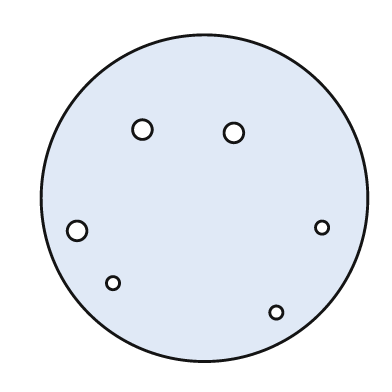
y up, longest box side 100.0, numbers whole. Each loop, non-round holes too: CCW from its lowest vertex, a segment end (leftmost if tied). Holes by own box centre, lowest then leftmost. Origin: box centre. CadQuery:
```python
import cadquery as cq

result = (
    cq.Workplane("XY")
    .moveTo(0.0, 0.0)
    .circle(50.0)
    .moveTo(22.0, -35.0)
    .circle(2.0)
    .moveTo(-28.0, -26.0)
    .circle(2.0)
    .moveTo(-39.0, -10.0)
    .circle(3.0)
    .moveTo(36.0, -9.0)
    .circle(2.0)
    .moveTo(9.0, 20.0)
    .circle(3.0)
    .moveTo(-19.0, 21.0)
    .circle(3.0)
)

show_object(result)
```